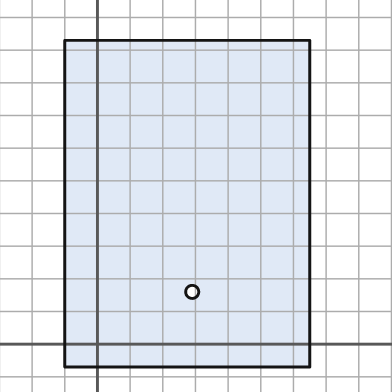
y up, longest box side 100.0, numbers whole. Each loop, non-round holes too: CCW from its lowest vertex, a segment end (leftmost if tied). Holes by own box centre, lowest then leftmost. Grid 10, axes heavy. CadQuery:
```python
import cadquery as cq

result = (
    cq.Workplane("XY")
    .moveTo(-10.0, -7.0)
    .lineTo(65.0, -7.0)
    .lineTo(65.0, 93.0)
    .lineTo(-10.0, 93.0)
    .close()
    .moveTo(29.0, 16.0)
    .circle(2.0)
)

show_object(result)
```